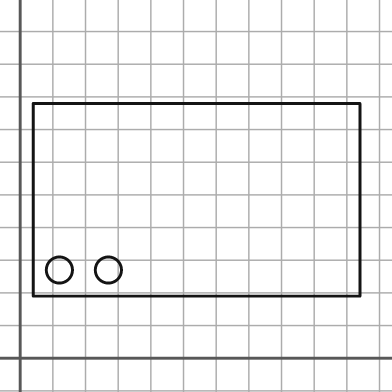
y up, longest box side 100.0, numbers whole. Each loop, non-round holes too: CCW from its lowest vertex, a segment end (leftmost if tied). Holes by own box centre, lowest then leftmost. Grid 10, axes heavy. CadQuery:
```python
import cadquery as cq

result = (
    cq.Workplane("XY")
    .moveTo(4.0, 19.0)
    .lineTo(104.0, 19.0)
    .lineTo(104.0, 78.0)
    .lineTo(4.0, 78.0)
    .close()
    .moveTo(12.0, 27.0)
    .circle(4.0)
    .moveTo(27.0, 27.0)
    .circle(4.0)
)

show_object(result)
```